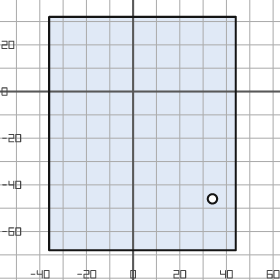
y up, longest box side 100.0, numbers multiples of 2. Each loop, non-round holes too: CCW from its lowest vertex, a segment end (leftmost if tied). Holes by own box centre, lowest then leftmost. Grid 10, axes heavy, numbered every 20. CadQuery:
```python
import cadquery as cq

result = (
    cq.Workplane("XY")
    .moveTo(-36.0, -68.0)
    .lineTo(44.0, -68.0)
    .lineTo(44.0, 32.0)
    .lineTo(-36.0, 32.0)
    .close()
    .moveTo(34.0, -46.0)
    .circle(2.0)
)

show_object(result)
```